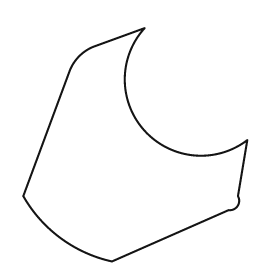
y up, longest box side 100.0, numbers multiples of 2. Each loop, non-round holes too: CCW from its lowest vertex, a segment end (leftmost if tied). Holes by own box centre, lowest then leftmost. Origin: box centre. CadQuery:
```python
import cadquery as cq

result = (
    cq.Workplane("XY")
    .moveTo(-10.0, -50.0)
    .lineTo(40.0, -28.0)
    .threePointArc((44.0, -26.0), (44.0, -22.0))
    .lineTo(48.0, 2.0)
    .threePointArc((4.0, 6.0), (4.0, 50.0))
    .lineTo(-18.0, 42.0)
    .threePointArc((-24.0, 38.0), (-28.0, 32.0))
    .lineTo(-48.0, -22.0)
    .threePointArc((-32.0, -40.0), (-10.0, -50.0))
    .close()
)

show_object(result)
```